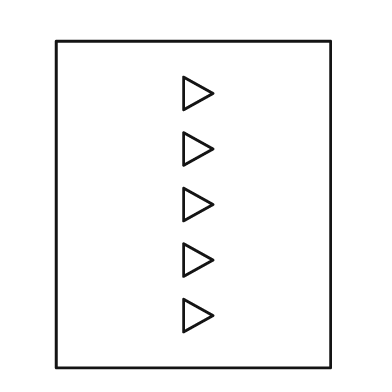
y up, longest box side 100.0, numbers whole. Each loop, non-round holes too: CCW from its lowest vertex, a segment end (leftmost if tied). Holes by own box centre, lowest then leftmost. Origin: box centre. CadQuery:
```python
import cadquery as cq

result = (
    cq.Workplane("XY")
    .moveTo(-42.0, -50.0)
    .lineTo(42.0, -50.0)
    .lineTo(42.0, 50.0)
    .lineTo(-42.0, 50.0)
    .close()
    .moveTo(-3.0, -39.0)
    .lineTo(6.0, -34.0)
    .lineTo(-3.0, -29.0)
    .close()
    .moveTo(-3.0, -22.0)
    .lineTo(6.0, -17.0)
    .lineTo(-3.0, -12.0)
    .close()
    .moveTo(-3.0, -5.0)
    .lineTo(6.0, 0.0)
    .lineTo(-3.0, 5.0)
    .close()
    .moveTo(-3.0, 12.0)
    .lineTo(6.0, 17.0)
    .lineTo(-3.0, 22.0)
    .close()
    .moveTo(-3.0, 29.0)
    .lineTo(6.0, 34.0)
    .lineTo(-3.0, 39.0)
    .close()
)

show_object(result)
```